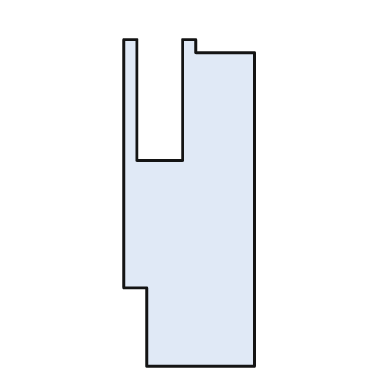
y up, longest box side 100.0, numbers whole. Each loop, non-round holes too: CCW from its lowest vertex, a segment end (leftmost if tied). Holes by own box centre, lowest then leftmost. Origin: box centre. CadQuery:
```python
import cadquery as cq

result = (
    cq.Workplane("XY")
    .moveTo(-13.0, -50.0)
    .lineTo(20.0, -50.0)
    .lineTo(20.0, 46.0)
    .lineTo(2.0, 46.0)
    .lineTo(2.0, 50.0)
    .lineTo(-2.0, 50.0)
    .lineTo(-2.0, 13.0)
    .lineTo(-16.0, 13.0)
    .lineTo(-16.0, 50.0)
    .lineTo(-20.0, 50.0)
    .lineTo(-20.0, -26.0)
    .lineTo(-13.0, -26.0)
    .close()
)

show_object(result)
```